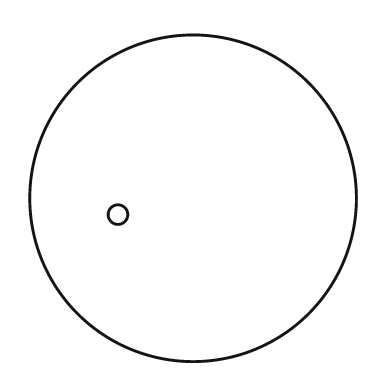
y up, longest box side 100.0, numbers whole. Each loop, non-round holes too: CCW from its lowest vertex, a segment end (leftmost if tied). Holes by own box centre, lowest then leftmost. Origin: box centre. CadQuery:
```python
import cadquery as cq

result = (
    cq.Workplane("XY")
    .moveTo(0.0, 0.0)
    .circle(50.0)
    .moveTo(-23.0, -5.0)
    .circle(3.0)
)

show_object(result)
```